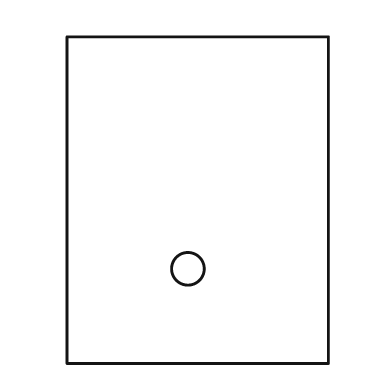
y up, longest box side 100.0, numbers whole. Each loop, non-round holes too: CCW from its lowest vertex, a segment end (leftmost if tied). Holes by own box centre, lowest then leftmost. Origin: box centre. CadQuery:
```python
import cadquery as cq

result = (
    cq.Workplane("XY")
    .moveTo(-40.0, -50.0)
    .lineTo(40.0, -50.0)
    .lineTo(40.0, 50.0)
    .lineTo(-40.0, 50.0)
    .close()
    .moveTo(-3.0, -21.0)
    .circle(5.0)
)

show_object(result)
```